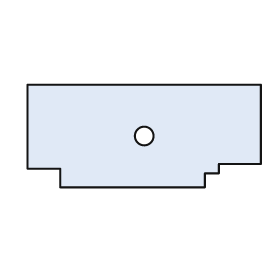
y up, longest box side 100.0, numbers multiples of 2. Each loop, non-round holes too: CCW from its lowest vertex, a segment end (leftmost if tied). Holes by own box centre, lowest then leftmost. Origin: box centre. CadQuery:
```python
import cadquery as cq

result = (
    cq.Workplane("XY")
    .moveTo(-36.0, -22.0)
    .lineTo(26.0, -22.0)
    .lineTo(26.0, -16.0)
    .lineTo(32.0, -16.0)
    .lineTo(32.0, -12.0)
    .lineTo(50.0, -12.0)
    .lineTo(50.0, 22.0)
    .lineTo(-50.0, 22.0)
    .lineTo(-50.0, -14.0)
    .lineTo(-36.0, -14.0)
    .close()
    .moveTo(0.0, 0.0)
    .circle(4.0)
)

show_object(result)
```